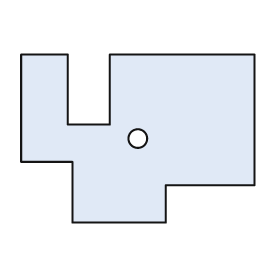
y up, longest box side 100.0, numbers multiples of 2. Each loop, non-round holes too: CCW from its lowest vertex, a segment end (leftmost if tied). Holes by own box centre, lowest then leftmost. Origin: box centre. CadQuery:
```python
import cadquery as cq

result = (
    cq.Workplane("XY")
    .moveTo(-28.0, -36.0)
    .lineTo(12.0, -36.0)
    .lineTo(12.0, -20.0)
    .lineTo(50.0, -20.0)
    .lineTo(50.0, 36.0)
    .lineTo(-12.0, 36.0)
    .lineTo(-12.0, 6.0)
    .lineTo(-30.0, 6.0)
    .lineTo(-30.0, 36.0)
    .lineTo(-50.0, 36.0)
    .lineTo(-50.0, -10.0)
    .lineTo(-28.0, -10.0)
    .close()
    .moveTo(0.0, 0.0)
    .circle(4.0)
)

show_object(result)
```